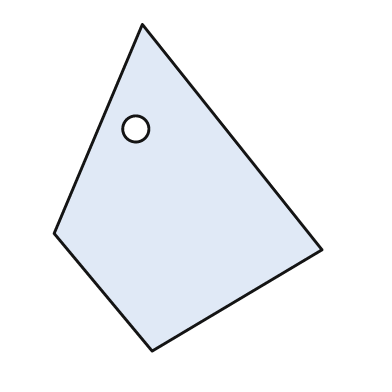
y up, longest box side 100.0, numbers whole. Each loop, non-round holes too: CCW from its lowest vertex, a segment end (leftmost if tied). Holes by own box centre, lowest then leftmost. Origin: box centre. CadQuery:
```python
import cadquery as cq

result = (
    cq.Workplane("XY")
    .moveTo(-11.0, -50.0)
    .lineTo(41.0, -19.0)
    .lineTo(-14.0, 50.0)
    .lineTo(-41.0, -14.0)
    .close()
    .moveTo(-16.0, 18.0)
    .circle(4.0)
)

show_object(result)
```